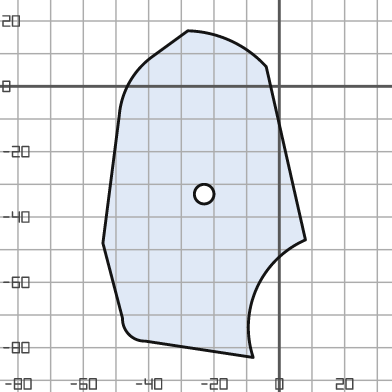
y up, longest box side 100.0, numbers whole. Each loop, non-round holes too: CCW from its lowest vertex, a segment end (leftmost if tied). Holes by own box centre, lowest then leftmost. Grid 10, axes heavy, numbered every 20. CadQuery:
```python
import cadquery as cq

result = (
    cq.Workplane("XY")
    .moveTo(-8.0, -83.0)
    .threePointArc((-7.0, -62.0), (8.0, -47.0))
    .lineTo(-4.0, 6.0)
    .threePointArc((-15.0, 14.0), (-28.0, 17.0))
    .lineTo(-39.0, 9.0)
    .threePointArc((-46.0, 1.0), (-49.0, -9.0))
    .lineTo(-54.0, -48.0)
    .lineTo(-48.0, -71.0)
    .threePointArc((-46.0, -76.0), (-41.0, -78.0))
    .close()
    .moveTo(-23.0, -33.0)
    .circle(3.0)
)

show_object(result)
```